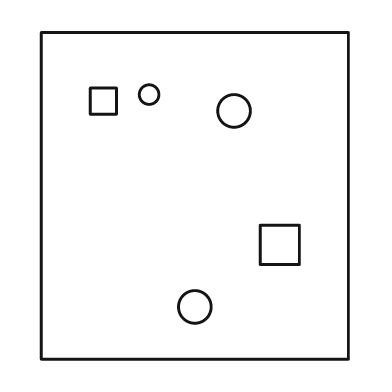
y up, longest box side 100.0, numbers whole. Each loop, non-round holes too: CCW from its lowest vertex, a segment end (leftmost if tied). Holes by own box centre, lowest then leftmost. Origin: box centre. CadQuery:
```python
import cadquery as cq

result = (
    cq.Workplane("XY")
    .moveTo(-47.0, -50.0)
    .lineTo(47.0, -50.0)
    .lineTo(47.0, 50.0)
    .lineTo(-47.0, 50.0)
    .close()
    .moveTo(0.0, -34.0)
    .circle(5.0)
    .moveTo(20.0, -21.0)
    .lineTo(32.0, -21.0)
    .lineTo(32.0, -9.0)
    .lineTo(20.0, -9.0)
    .close()
    .moveTo(12.0, 26.0)
    .circle(5.0)
    .moveTo(-32.0, 25.0)
    .lineTo(-24.0, 25.0)
    .lineTo(-24.0, 33.0)
    .lineTo(-32.0, 33.0)
    .close()
    .moveTo(-14.0, 31.0)
    .circle(3.0)
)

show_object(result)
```